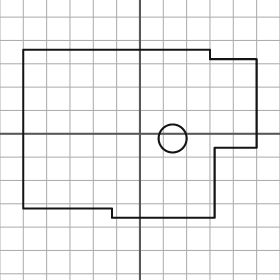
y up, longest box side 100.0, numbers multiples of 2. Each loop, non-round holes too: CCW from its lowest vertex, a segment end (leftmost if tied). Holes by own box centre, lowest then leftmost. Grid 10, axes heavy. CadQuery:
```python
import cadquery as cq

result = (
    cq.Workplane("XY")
    .moveTo(-12.0, -36.0)
    .lineTo(32.0, -36.0)
    .lineTo(32.0, -6.0)
    .lineTo(50.0, -6.0)
    .lineTo(50.0, 32.0)
    .lineTo(30.0, 32.0)
    .lineTo(30.0, 36.0)
    .lineTo(-50.0, 36.0)
    .lineTo(-50.0, -32.0)
    .lineTo(-12.0, -32.0)
    .close()
    .moveTo(14.0, -2.0)
    .circle(6.0)
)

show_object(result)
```